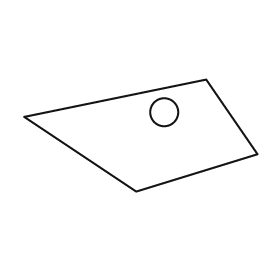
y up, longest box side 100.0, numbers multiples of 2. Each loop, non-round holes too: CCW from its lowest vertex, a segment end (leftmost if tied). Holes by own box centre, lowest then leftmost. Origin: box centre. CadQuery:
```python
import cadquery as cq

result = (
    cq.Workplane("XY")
    .moveTo(-2.0, -24.0)
    .lineTo(50.0, -8.0)
    .lineTo(28.0, 24.0)
    .lineTo(-50.0, 8.0)
    .close()
    .moveTo(10.0, 10.0)
    .circle(6.0)
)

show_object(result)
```